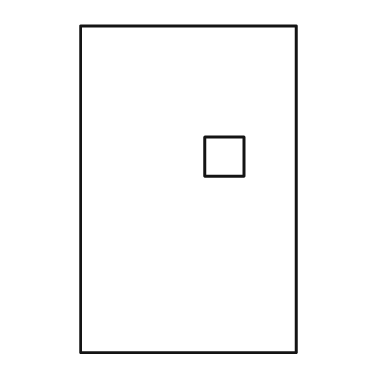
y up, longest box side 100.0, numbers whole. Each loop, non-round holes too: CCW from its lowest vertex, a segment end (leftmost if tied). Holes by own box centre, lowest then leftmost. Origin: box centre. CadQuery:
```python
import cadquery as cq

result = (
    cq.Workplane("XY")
    .moveTo(-33.0, -50.0)
    .lineTo(33.0, -50.0)
    .lineTo(33.0, 50.0)
    .lineTo(-33.0, 50.0)
    .close()
    .moveTo(5.0, 4.0)
    .lineTo(17.0, 4.0)
    .lineTo(17.0, 16.0)
    .lineTo(5.0, 16.0)
    .close()
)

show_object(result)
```